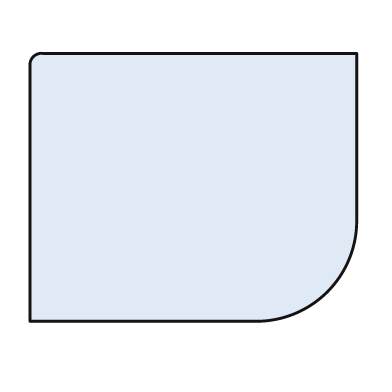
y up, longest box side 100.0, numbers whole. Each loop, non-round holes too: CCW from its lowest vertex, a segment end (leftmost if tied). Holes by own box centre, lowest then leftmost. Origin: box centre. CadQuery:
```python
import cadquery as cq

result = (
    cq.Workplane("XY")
    .moveTo(-50.0, -41.0)
    .lineTo(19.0, -41.0)
    .threePointArc((41.0, -32.0), (50.0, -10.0))
    .lineTo(50.0, 41.0)
    .lineTo(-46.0, 41.0)
    .threePointArc((-49.0, 40.0), (-50.0, 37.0))
    .close()
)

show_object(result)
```